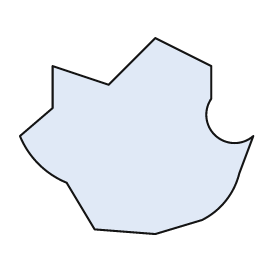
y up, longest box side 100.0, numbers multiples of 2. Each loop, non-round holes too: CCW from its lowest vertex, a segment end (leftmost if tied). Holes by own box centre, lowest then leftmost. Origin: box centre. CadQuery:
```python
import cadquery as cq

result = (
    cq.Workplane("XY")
    .moveTo(8.0, -42.0)
    .lineTo(28.0, -36.0)
    .threePointArc((38.0, -28.0), (44.0, -16.0))
    .lineTo(50.0, 0.0)
    .threePointArc((34.0, 0.0), (32.0, 16.0))
    .lineTo(32.0, 30.0)
    .lineTo(8.0, 42.0)
    .lineTo(-12.0, 22.0)
    .lineTo(-36.0, 30.0)
    .lineTo(-36.0, 12.0)
    .lineTo(-50.0, 0.0)
    .threePointArc((-42.0, -12.0), (-30.0, -20.0))
    .lineTo(-18.0, -40.0)
    .close()
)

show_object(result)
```